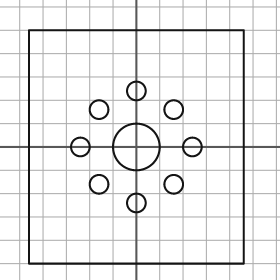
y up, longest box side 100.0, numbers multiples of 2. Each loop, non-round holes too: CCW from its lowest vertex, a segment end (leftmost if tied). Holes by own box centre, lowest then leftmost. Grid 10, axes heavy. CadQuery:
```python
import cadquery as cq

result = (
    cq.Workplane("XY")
    .moveTo(-46.0, -50.0)
    .lineTo(46.0, -50.0)
    .lineTo(46.0, 50.0)
    .lineTo(-46.0, 50.0)
    .close()
    .moveTo(0.0, -24.0)
    .circle(4.0)
    .moveTo(-16.0, -16.0)
    .circle(4.0)
    .moveTo(16.0, -16.0)
    .circle(4.0)
    .moveTo(-24.0, 0.0)
    .circle(4.0)
    .moveTo(0.0, 0.0)
    .circle(10.0)
    .moveTo(24.0, 0.0)
    .circle(4.0)
    .moveTo(-16.0, 16.0)
    .circle(4.0)
    .moveTo(16.0, 16.0)
    .circle(4.0)
    .moveTo(0.0, 24.0)
    .circle(4.0)
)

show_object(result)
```